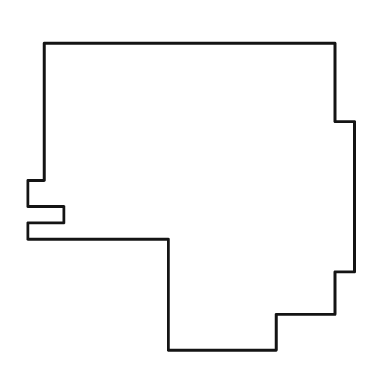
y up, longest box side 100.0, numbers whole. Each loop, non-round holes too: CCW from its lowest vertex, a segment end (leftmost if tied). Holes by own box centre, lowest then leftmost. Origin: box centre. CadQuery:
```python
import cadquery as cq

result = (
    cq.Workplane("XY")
    .moveTo(-7.0, -47.0)
    .lineTo(26.0, -47.0)
    .lineTo(26.0, -36.0)
    .lineTo(44.0, -36.0)
    .lineTo(44.0, -23.0)
    .lineTo(50.0, -23.0)
    .lineTo(50.0, 23.0)
    .lineTo(44.0, 23.0)
    .lineTo(44.0, 47.0)
    .lineTo(-45.0, 47.0)
    .lineTo(-45.0, 5.0)
    .lineTo(-50.0, 5.0)
    .lineTo(-50.0, -3.0)
    .lineTo(-39.0, -3.0)
    .lineTo(-39.0, -8.0)
    .lineTo(-50.0, -8.0)
    .lineTo(-50.0, -13.0)
    .lineTo(-7.0, -13.0)
    .close()
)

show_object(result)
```